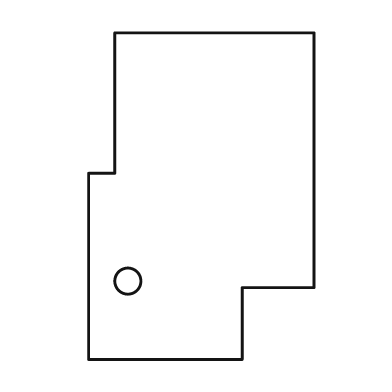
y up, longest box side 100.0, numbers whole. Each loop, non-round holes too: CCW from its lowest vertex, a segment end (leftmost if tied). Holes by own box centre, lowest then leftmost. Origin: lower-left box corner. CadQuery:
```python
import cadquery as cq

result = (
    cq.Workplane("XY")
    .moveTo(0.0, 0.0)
    .lineTo(47.0, 0.0)
    .lineTo(47.0, 22.0)
    .lineTo(69.0, 22.0)
    .lineTo(69.0, 100.0)
    .lineTo(8.0, 100.0)
    .lineTo(8.0, 57.0)
    .lineTo(0.0, 57.0)
    .close()
    .moveTo(12.0, 24.0)
    .circle(4.0)
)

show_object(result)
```